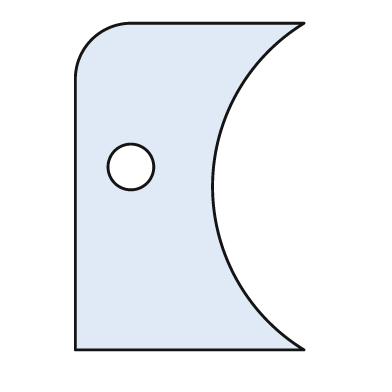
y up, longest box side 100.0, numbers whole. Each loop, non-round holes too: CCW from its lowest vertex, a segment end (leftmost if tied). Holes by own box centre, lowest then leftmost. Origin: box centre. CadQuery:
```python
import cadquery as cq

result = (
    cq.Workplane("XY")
    .moveTo(-35.0, -50.0)
    .lineTo(35.0, -50.0)
    .threePointArc((7.0, 0.0), (35.0, 50.0))
    .lineTo(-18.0, 50.0)
    .threePointArc((-30.0, 45.0), (-35.0, 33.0))
    .close()
    .moveTo(-18.0, 6.0)
    .circle(7.0)
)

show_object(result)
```